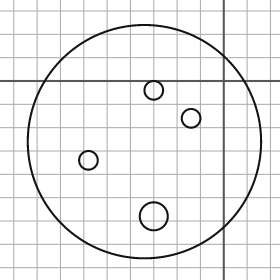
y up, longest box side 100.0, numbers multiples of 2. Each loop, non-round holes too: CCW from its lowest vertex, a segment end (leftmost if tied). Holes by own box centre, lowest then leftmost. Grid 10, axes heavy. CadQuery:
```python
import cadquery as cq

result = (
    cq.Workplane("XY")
    .moveTo(-34.0, -26.0)
    .circle(50.0)
    .moveTo(-30.0, -58.0)
    .circle(6.0)
    .moveTo(-58.0, -34.0)
    .circle(4.0)
    .moveTo(-14.0, -16.0)
    .circle(4.0)
    .moveTo(-30.0, -4.0)
    .circle(4.0)
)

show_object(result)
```